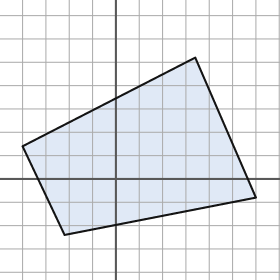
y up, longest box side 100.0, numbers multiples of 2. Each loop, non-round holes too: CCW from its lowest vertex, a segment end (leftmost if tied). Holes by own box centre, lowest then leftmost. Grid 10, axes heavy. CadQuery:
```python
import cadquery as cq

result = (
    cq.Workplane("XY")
    .moveTo(-22.0, -24.0)
    .lineTo(60.0, -8.0)
    .lineTo(34.0, 52.0)
    .lineTo(-40.0, 14.0)
    .close()
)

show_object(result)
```